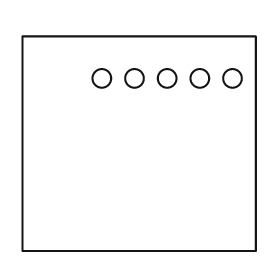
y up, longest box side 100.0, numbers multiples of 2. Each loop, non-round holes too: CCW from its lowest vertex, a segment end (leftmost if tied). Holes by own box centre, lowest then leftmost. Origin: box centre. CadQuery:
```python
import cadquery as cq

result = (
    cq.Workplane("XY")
    .moveTo(-50.0, -46.0)
    .lineTo(50.0, -46.0)
    .lineTo(50.0, 46.0)
    .lineTo(-50.0, 46.0)
    .close()
    .moveTo(-16.0, 28.0)
    .circle(4.0)
    .moveTo(-2.0, 28.0)
    .circle(4.0)
    .moveTo(12.0, 28.0)
    .circle(4.0)
    .moveTo(26.0, 28.0)
    .circle(4.0)
    .moveTo(40.0, 28.0)
    .circle(4.0)
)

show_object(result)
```